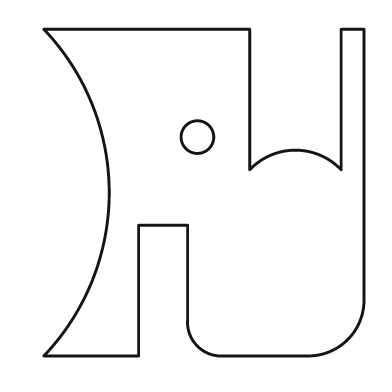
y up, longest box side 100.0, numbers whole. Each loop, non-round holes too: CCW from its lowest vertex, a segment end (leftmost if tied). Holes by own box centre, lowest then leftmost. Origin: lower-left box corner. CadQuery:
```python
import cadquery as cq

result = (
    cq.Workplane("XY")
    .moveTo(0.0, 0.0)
    .lineTo(29.0, 0.0)
    .lineTo(29.0, 40.0)
    .lineTo(44.0, 40.0)
    .lineTo(44.0, 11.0)
    .threePointArc((47.0, 3.0), (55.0, 0.0))
    .lineTo(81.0, 0.0)
    .threePointArc((93.0, 5.0), (98.0, 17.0))
    .lineTo(98.0, 100.0)
    .lineTo(91.0, 100.0)
    .lineTo(91.0, 57.0)
    .threePointArc((77.0, 63.0), (63.0, 57.0))
    .lineTo(63.0, 100.0)
    .lineTo(0.0, 100.0)
    .threePointArc((20.0, 50.0), (0.0, 0.0))
    .close()
    .moveTo(47.0, 67.0)
    .circle(5.0)
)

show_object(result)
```